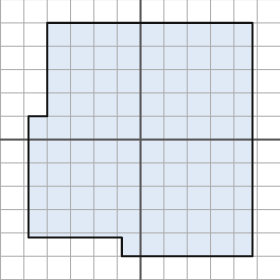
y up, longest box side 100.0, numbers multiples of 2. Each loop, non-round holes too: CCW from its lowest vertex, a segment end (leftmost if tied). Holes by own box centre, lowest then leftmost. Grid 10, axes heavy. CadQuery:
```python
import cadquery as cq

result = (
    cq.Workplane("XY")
    .moveTo(-8.0, -50.0)
    .lineTo(48.0, -50.0)
    .lineTo(48.0, 50.0)
    .lineTo(-40.0, 50.0)
    .lineTo(-40.0, 10.0)
    .lineTo(-48.0, 10.0)
    .lineTo(-48.0, -42.0)
    .lineTo(-8.0, -42.0)
    .close()
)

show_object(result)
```